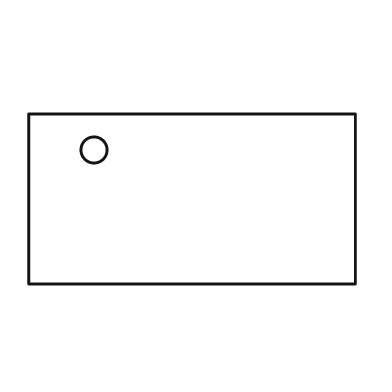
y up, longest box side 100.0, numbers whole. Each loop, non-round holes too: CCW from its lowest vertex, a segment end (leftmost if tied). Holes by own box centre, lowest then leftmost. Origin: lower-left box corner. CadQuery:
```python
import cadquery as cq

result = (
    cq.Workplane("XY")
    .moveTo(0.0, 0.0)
    .lineTo(100.0, 0.0)
    .lineTo(100.0, 52.0)
    .lineTo(0.0, 52.0)
    .close()
    .moveTo(20.0, 41.0)
    .circle(4.0)
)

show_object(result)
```